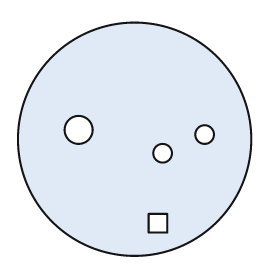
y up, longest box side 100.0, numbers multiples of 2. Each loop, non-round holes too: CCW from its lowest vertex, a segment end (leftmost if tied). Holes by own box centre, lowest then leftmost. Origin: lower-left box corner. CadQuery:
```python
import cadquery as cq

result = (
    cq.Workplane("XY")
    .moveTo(50.0, 50.0)
    .circle(50.0)
    .moveTo(56.0, 10.0)
    .lineTo(64.0, 10.0)
    .lineTo(64.0, 18.0)
    .lineTo(56.0, 18.0)
    .close()
    .moveTo(62.0, 44.0)
    .circle(4.0)
    .moveTo(80.0, 52.0)
    .circle(4.0)
    .moveTo(26.0, 54.0)
    .circle(6.0)
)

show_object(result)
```